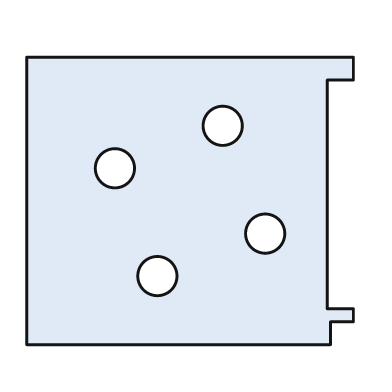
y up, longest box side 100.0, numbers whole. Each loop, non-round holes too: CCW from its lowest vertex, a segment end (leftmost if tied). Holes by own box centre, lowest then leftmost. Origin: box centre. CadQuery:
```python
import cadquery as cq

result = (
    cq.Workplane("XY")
    .moveTo(-50.0, -44.0)
    .lineTo(43.0, -44.0)
    .lineTo(43.0, -37.0)
    .lineTo(50.0, -37.0)
    .lineTo(50.0, -33.0)
    .lineTo(42.0, -33.0)
    .lineTo(42.0, 37.0)
    .lineTo(50.0, 37.0)
    .lineTo(50.0, 44.0)
    .lineTo(-50.0, 44.0)
    .close()
    .moveTo(-10.0, -23.0)
    .circle(6.0)
    .moveTo(23.0, -10.0)
    .circle(6.0)
    .moveTo(-23.0, 10.0)
    .circle(6.0)
    .moveTo(10.0, 23.0)
    .circle(6.0)
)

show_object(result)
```